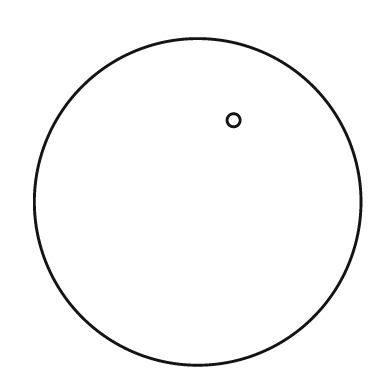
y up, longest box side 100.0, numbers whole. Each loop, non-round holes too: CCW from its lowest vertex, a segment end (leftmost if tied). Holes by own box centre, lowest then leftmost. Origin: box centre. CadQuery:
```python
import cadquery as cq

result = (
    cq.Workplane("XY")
    .moveTo(0.0, 0.0)
    .circle(50.0)
    .moveTo(11.0, 25.0)
    .circle(2.0)
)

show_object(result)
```